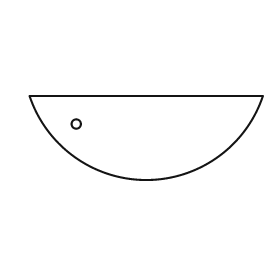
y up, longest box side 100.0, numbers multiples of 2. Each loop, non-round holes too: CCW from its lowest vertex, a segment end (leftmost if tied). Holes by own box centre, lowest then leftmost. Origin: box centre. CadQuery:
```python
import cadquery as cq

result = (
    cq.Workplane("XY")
    .moveTo(-50.0, 18.0)
    .threePointArc((0.0, -18.0), (50.0, 18.0))
    .close()
    .moveTo(-30.0, 6.0)
    .circle(2.0)
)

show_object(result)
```